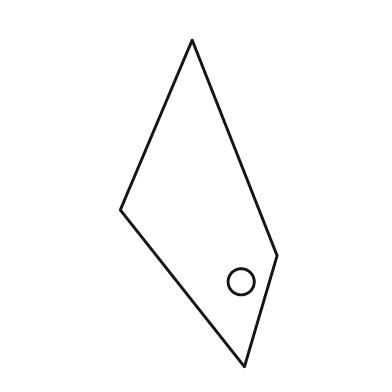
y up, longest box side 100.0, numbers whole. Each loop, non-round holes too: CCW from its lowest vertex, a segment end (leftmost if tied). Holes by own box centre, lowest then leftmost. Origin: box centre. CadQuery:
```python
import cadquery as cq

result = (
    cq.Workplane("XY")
    .moveTo(14.0, -50.0)
    .lineTo(24.0, -16.0)
    .lineTo(-2.0, 50.0)
    .lineTo(-24.0, -2.0)
    .close()
    .moveTo(13.0, -24.0)
    .circle(4.0)
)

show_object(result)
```